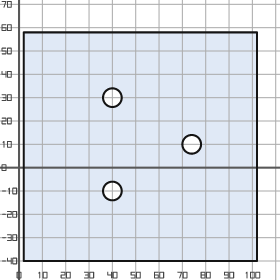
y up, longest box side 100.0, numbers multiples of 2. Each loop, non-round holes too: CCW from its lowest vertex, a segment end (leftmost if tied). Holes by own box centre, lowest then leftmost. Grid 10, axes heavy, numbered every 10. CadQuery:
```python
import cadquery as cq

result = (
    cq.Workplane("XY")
    .moveTo(2.0, -40.0)
    .lineTo(102.0, -40.0)
    .lineTo(102.0, 58.0)
    .lineTo(2.0, 58.0)
    .close()
    .moveTo(40.0, -10.0)
    .circle(4.0)
    .moveTo(74.0, 10.0)
    .circle(4.0)
    .moveTo(40.0, 30.0)
    .circle(4.0)
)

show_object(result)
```